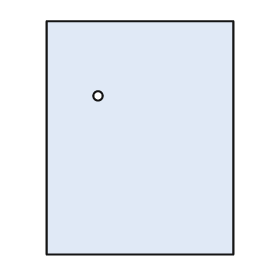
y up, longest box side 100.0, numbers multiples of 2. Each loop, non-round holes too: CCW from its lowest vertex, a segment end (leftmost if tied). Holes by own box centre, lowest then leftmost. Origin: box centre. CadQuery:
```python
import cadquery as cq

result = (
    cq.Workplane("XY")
    .moveTo(-40.0, -50.0)
    .lineTo(40.0, -50.0)
    .lineTo(40.0, 50.0)
    .lineTo(-40.0, 50.0)
    .close()
    .moveTo(-18.0, 18.0)
    .circle(2.0)
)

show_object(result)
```